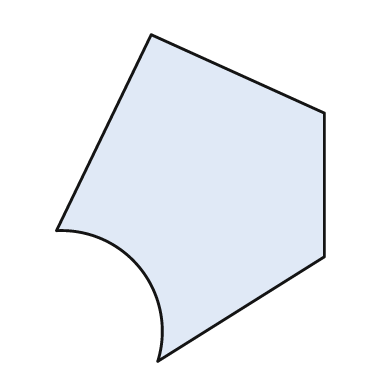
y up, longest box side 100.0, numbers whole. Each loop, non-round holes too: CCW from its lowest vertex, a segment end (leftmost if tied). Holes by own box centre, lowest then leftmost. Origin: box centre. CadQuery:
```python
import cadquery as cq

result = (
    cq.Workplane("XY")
    .moveTo(-10.0, -50.0)
    .lineTo(41.0, -18.0)
    .lineTo(41.0, 26.0)
    .lineTo(-12.0, 50.0)
    .lineTo(-41.0, -10.0)
    .threePointArc((-15.0, -22.0), (-10.0, -50.0))
    .close()
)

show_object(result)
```